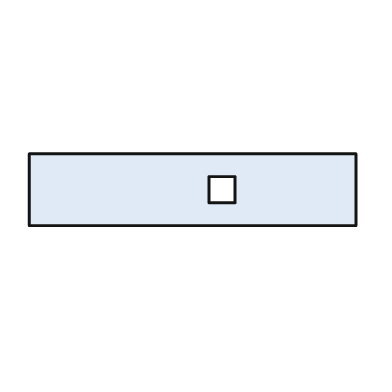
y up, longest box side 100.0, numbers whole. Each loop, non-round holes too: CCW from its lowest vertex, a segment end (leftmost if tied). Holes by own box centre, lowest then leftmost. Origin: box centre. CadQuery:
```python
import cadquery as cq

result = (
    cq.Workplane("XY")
    .moveTo(-50.0, -11.0)
    .lineTo(50.0, -11.0)
    .lineTo(50.0, 11.0)
    .lineTo(-50.0, 11.0)
    .close()
    .moveTo(5.0, -4.0)
    .lineTo(13.0, -4.0)
    .lineTo(13.0, 4.0)
    .lineTo(5.0, 4.0)
    .close()
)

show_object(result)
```